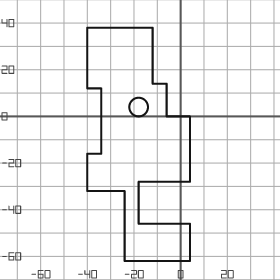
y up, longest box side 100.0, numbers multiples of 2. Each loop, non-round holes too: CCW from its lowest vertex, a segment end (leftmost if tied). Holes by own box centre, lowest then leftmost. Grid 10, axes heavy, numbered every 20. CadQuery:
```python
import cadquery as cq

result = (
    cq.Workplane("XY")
    .moveTo(-24.0, -62.0)
    .lineTo(4.0, -62.0)
    .lineTo(4.0, -46.0)
    .lineTo(-18.0, -46.0)
    .lineTo(-18.0, -28.0)
    .lineTo(4.0, -28.0)
    .lineTo(4.0, 0.0)
    .lineTo(-6.0, 0.0)
    .lineTo(-6.0, 14.0)
    .lineTo(-12.0, 14.0)
    .lineTo(-12.0, 38.0)
    .lineTo(-40.0, 38.0)
    .lineTo(-40.0, 12.0)
    .lineTo(-34.0, 12.0)
    .lineTo(-34.0, -16.0)
    .lineTo(-40.0, -16.0)
    .lineTo(-40.0, -32.0)
    .lineTo(-24.0, -32.0)
    .close()
    .moveTo(-18.0, 4.0)
    .circle(4.0)
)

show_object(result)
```